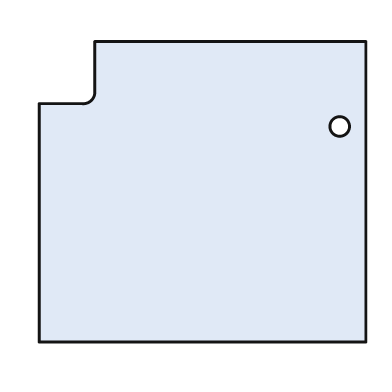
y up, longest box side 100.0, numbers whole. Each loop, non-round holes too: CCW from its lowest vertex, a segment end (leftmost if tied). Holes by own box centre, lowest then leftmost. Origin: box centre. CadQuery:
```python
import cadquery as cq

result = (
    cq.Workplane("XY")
    .moveTo(-50.0, -46.0)
    .lineTo(50.0, -46.0)
    .lineTo(50.0, 46.0)
    .lineTo(-33.0, 46.0)
    .lineTo(-33.0, 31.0)
    .threePointArc((-34.0, 28.0), (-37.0, 27.0))
    .lineTo(-50.0, 27.0)
    .close()
    .moveTo(42.0, 20.0)
    .circle(3.0)
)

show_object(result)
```